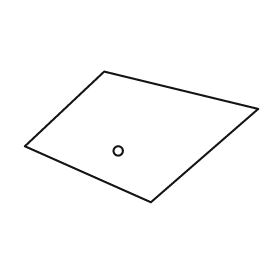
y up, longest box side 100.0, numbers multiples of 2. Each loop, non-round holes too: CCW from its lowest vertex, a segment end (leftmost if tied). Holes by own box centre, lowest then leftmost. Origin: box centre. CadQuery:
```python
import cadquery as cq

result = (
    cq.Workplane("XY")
    .moveTo(4.0, -28.0)
    .lineTo(50.0, 12.0)
    .lineTo(-16.0, 28.0)
    .lineTo(-50.0, -4.0)
    .close()
    .moveTo(-10.0, -6.0)
    .circle(2.0)
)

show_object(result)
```